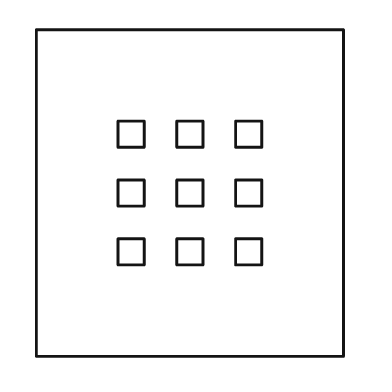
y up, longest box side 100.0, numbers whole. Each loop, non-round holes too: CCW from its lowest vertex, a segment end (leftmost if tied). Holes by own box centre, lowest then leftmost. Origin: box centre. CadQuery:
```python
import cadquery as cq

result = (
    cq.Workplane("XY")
    .moveTo(-47.0, -50.0)
    .lineTo(47.0, -50.0)
    .lineTo(47.0, 50.0)
    .lineTo(-47.0, 50.0)
    .close()
    .moveTo(-22.0, -22.0)
    .lineTo(-14.0, -22.0)
    .lineTo(-14.0, -14.0)
    .lineTo(-22.0, -14.0)
    .close()
    .moveTo(-4.0, -22.0)
    .lineTo(4.0, -22.0)
    .lineTo(4.0, -14.0)
    .lineTo(-4.0, -14.0)
    .close()
    .moveTo(14.0, -22.0)
    .lineTo(22.0, -22.0)
    .lineTo(22.0, -14.0)
    .lineTo(14.0, -14.0)
    .close()
    .moveTo(-22.0, -4.0)
    .lineTo(-14.0, -4.0)
    .lineTo(-14.0, 4.0)
    .lineTo(-22.0, 4.0)
    .close()
    .moveTo(-4.0, -4.0)
    .lineTo(4.0, -4.0)
    .lineTo(4.0, 4.0)
    .lineTo(-4.0, 4.0)
    .close()
    .moveTo(14.0, -4.0)
    .lineTo(22.0, -4.0)
    .lineTo(22.0, 4.0)
    .lineTo(14.0, 4.0)
    .close()
    .moveTo(-22.0, 14.0)
    .lineTo(-14.0, 14.0)
    .lineTo(-14.0, 22.0)
    .lineTo(-22.0, 22.0)
    .close()
    .moveTo(-4.0, 14.0)
    .lineTo(4.0, 14.0)
    .lineTo(4.0, 22.0)
    .lineTo(-4.0, 22.0)
    .close()
    .moveTo(14.0, 14.0)
    .lineTo(22.0, 14.0)
    .lineTo(22.0, 22.0)
    .lineTo(14.0, 22.0)
    .close()
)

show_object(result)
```